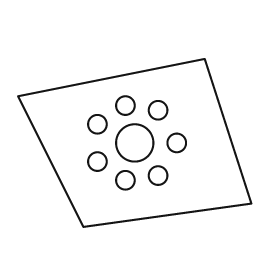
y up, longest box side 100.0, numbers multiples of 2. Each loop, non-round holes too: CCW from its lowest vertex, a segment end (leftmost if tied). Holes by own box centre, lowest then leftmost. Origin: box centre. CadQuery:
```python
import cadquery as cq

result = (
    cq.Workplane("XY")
    .moveTo(-22.0, -36.0)
    .lineTo(50.0, -26.0)
    .lineTo(30.0, 36.0)
    .lineTo(-50.0, 20.0)
    .close()
    .moveTo(-4.0, -16.0)
    .circle(4.0)
    .moveTo(10.0, -14.0)
    .circle(4.0)
    .moveTo(-16.0, -8.0)
    .circle(4.0)
    .moveTo(0.0, 0.0)
    .circle(8.0)
    .moveTo(18.0, 0.0)
    .circle(4.0)
    .moveTo(-16.0, 8.0)
    .circle(4.0)
    .moveTo(10.0, 14.0)
    .circle(4.0)
    .moveTo(-4.0, 16.0)
    .circle(4.0)
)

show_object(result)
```